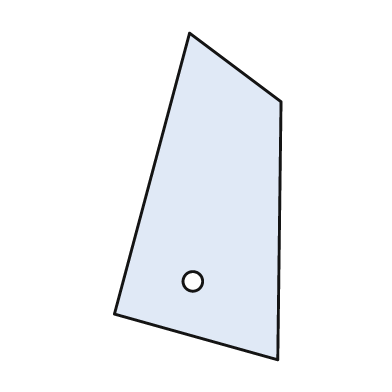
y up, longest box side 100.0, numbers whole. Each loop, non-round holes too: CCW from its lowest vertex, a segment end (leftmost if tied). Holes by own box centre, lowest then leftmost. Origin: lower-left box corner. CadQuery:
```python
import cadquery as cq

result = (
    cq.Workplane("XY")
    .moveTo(50.0, 0.0)
    .lineTo(51.0, 79.0)
    .lineTo(23.0, 100.0)
    .lineTo(0.0, 14.0)
    .close()
    .moveTo(24.0, 24.0)
    .circle(3.0)
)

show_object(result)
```